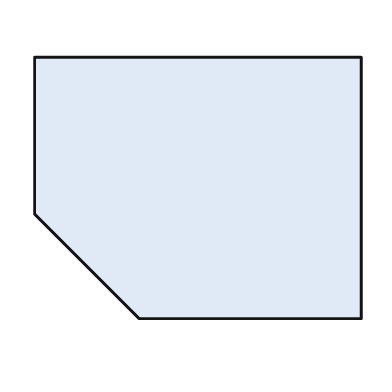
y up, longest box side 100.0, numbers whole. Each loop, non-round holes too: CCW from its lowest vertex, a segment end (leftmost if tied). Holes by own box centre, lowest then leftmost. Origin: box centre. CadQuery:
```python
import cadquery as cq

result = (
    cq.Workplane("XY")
    .moveTo(-18.0, -40.0)
    .lineTo(50.0, -40.0)
    .lineTo(50.0, 40.0)
    .lineTo(-50.0, 40.0)
    .lineTo(-50.0, -8.0)
    .close()
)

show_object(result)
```